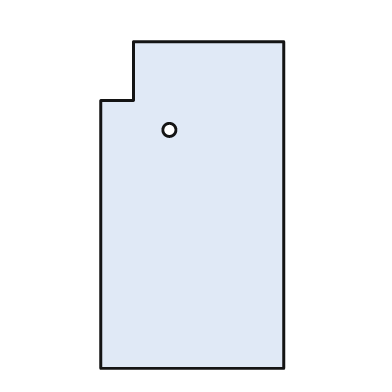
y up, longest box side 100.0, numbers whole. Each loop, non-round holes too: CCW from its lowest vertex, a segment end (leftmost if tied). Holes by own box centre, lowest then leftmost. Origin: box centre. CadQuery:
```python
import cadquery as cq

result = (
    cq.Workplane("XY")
    .moveTo(-28.0, -50.0)
    .lineTo(28.0, -50.0)
    .lineTo(28.0, 50.0)
    .lineTo(-18.0, 50.0)
    .lineTo(-18.0, 32.0)
    .lineTo(-28.0, 32.0)
    .close()
    .moveTo(-7.0, 23.0)
    .circle(2.0)
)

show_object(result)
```